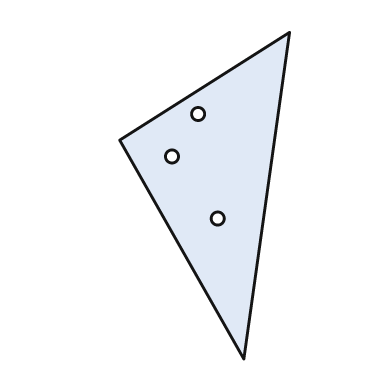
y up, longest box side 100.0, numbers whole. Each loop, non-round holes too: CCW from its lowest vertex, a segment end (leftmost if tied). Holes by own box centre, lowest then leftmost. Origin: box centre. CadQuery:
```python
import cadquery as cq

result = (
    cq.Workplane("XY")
    .moveTo(12.0, -50.0)
    .lineTo(26.0, 50.0)
    .lineTo(-26.0, 17.0)
    .close()
    .moveTo(4.0, -7.0)
    .circle(2.0)
    .moveTo(-10.0, 12.0)
    .circle(2.0)
    .moveTo(-2.0, 25.0)
    .circle(2.0)
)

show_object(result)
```